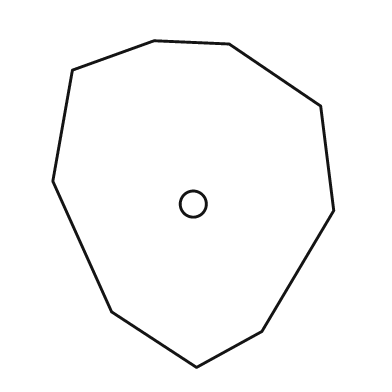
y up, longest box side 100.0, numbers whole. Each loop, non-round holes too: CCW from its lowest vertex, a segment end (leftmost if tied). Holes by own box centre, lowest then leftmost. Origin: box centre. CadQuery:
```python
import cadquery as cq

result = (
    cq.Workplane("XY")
    .moveTo(1.0, -50.0)
    .lineTo(21.0, -39.0)
    .lineTo(43.0, -2.0)
    .lineTo(39.0, 30.0)
    .lineTo(11.0, 49.0)
    .lineTo(-12.0, 50.0)
    .lineTo(-37.0, 41.0)
    .lineTo(-43.0, 7.0)
    .lineTo(-25.0, -33.0)
    .close()
    .moveTo(0.0, 0.0)
    .circle(4.0)
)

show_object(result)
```